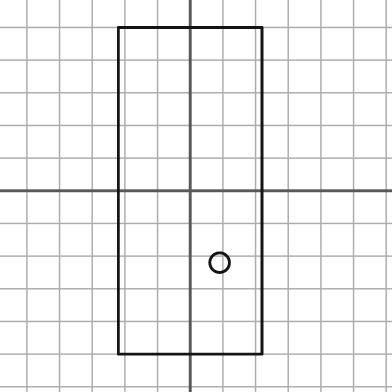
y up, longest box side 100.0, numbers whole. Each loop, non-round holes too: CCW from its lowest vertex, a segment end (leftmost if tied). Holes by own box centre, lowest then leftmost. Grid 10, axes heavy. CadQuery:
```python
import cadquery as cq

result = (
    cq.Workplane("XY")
    .moveTo(-22.0, -50.0)
    .lineTo(22.0, -50.0)
    .lineTo(22.0, 50.0)
    .lineTo(-22.0, 50.0)
    .close()
    .moveTo(9.0, -22.0)
    .circle(3.0)
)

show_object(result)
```